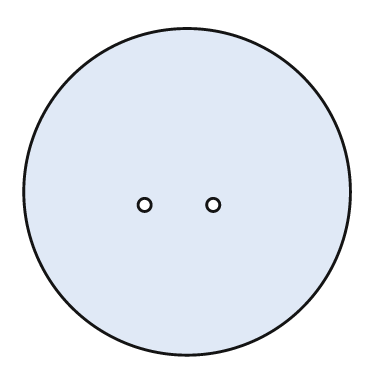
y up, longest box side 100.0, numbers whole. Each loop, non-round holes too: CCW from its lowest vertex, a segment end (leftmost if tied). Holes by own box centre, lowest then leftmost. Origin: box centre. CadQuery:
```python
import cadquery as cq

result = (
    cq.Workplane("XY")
    .moveTo(0.0, 0.0)
    .circle(50.0)
    .moveTo(-13.0, -4.0)
    .circle(2.0)
    .moveTo(8.0, -4.0)
    .circle(2.0)
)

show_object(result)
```